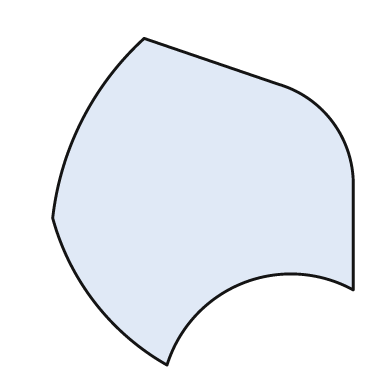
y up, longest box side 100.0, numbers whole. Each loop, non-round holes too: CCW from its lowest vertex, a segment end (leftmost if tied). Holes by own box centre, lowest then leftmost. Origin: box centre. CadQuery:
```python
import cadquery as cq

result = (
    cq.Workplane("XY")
    .moveTo(-11.0, -50.0)
    .threePointArc((12.0, -25.0), (46.0, -27.0))
    .lineTo(46.0, 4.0)
    .threePointArc((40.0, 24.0), (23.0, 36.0))
    .lineTo(-18.0, 50.0)
    .threePointArc((-37.0, 25.0), (-46.0, -5.0))
    .threePointArc((-33.0, -31.0), (-11.0, -50.0))
    .close()
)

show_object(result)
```